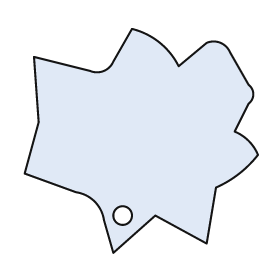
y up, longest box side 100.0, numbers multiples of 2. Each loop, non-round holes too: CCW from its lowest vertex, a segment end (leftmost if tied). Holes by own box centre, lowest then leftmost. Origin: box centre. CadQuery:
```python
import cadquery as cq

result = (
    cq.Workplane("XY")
    .moveTo(-12.0, -48.0)
    .lineTo(6.0, -32.0)
    .lineTo(28.0, -44.0)
    .lineTo(32.0, -20.0)
    .threePointArc((42.0, -14.0), (50.0, -6.0))
    .threePointArc((46.0, 0.0), (40.0, 4.0))
    .lineTo(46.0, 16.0)
    .threePointArc((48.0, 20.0), (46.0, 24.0))
    .lineTo(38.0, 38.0)
    .threePointArc((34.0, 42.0), (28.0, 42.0))
    .lineTo(16.0, 32.0)
    .threePointArc((8.0, 42.0), (-4.0, 48.0))
    .lineTo(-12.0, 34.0)
    .threePointArc((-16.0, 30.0), (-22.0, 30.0))
    .lineTo(-46.0, 36.0)
    .lineTo(-44.0, 8.0)
    .lineTo(-50.0, -14.0)
    .lineTo(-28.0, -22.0)
    .threePointArc((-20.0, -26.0), (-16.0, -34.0))
    .close()
    .moveTo(-8.0, -32.0)
    .circle(4.0)
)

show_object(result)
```